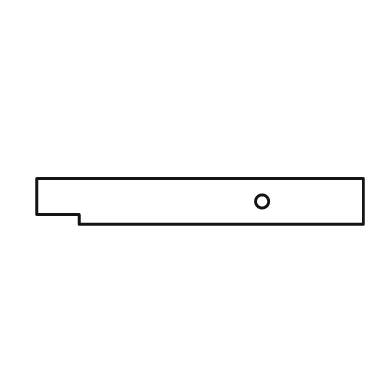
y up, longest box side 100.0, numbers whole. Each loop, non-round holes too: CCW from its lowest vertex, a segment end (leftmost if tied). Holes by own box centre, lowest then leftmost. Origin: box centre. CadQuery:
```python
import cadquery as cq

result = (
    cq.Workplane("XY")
    .moveTo(-37.0, -7.0)
    .lineTo(50.0, -7.0)
    .lineTo(50.0, 7.0)
    .lineTo(-50.0, 7.0)
    .lineTo(-50.0, -4.0)
    .lineTo(-37.0, -4.0)
    .close()
    .moveTo(19.0, 0.0)
    .circle(2.0)
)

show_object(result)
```